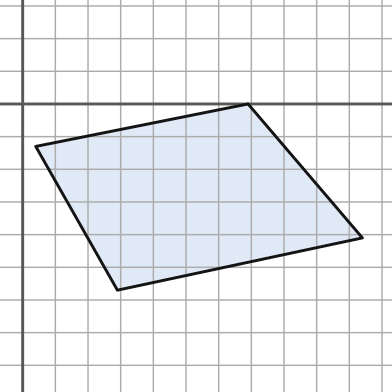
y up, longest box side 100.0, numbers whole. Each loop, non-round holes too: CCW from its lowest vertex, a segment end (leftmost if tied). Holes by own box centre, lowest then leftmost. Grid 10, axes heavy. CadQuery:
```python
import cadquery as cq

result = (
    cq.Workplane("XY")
    .moveTo(29.0, -57.0)
    .lineTo(104.0, -41.0)
    .lineTo(69.0, 0.0)
    .lineTo(4.0, -13.0)
    .close()
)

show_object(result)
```